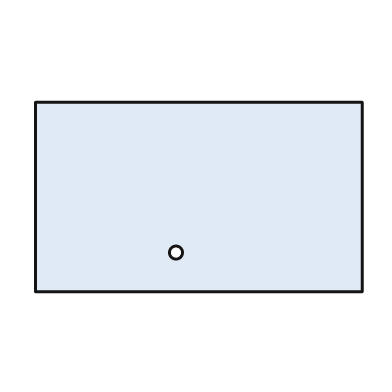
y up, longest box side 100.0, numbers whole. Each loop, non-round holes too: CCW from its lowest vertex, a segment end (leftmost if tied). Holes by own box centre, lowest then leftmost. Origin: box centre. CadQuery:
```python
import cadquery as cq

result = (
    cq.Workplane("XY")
    .moveTo(-50.0, -29.0)
    .lineTo(50.0, -29.0)
    .lineTo(50.0, 29.0)
    .lineTo(-50.0, 29.0)
    .close()
    .moveTo(-7.0, -17.0)
    .circle(2.0)
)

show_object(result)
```